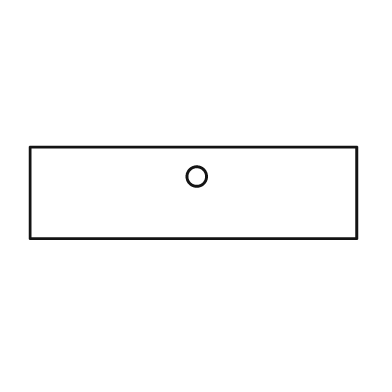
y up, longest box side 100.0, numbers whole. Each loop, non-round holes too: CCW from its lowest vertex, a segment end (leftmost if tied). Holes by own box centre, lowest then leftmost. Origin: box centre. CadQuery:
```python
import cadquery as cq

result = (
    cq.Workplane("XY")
    .moveTo(-50.0, -14.0)
    .lineTo(50.0, -14.0)
    .lineTo(50.0, 14.0)
    .lineTo(-50.0, 14.0)
    .close()
    .moveTo(1.0, 5.0)
    .circle(3.0)
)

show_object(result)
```